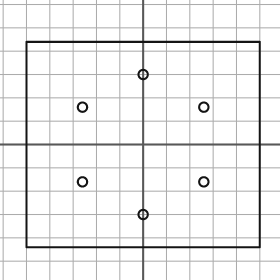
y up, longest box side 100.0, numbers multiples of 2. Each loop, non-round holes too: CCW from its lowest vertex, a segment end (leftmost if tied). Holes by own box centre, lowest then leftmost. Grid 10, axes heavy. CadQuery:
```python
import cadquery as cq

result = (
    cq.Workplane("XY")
    .moveTo(-50.0, -44.0)
    .lineTo(50.0, -44.0)
    .lineTo(50.0, 44.0)
    .lineTo(-50.0, 44.0)
    .close()
    .moveTo(0.0, -30.0)
    .circle(2.0)
    .moveTo(-26.0, -16.0)
    .circle(2.0)
    .moveTo(26.0, -16.0)
    .circle(2.0)
    .moveTo(-26.0, 16.0)
    .circle(2.0)
    .moveTo(26.0, 16.0)
    .circle(2.0)
    .moveTo(0.0, 30.0)
    .circle(2.0)
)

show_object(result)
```